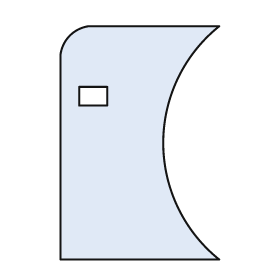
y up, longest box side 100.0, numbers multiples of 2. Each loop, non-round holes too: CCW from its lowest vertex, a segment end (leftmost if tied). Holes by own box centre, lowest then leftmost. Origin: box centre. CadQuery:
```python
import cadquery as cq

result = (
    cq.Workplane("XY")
    .moveTo(-34.0, -50.0)
    .lineTo(34.0, -50.0)
    .threePointArc((10.0, 0.0), (34.0, 50.0))
    .lineTo(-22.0, 50.0)
    .threePointArc((-30.0, 46.0), (-34.0, 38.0))
    .close()
    .moveTo(-26.0, 16.0)
    .lineTo(-14.0, 16.0)
    .lineTo(-14.0, 24.0)
    .lineTo(-26.0, 24.0)
    .close()
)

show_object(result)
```